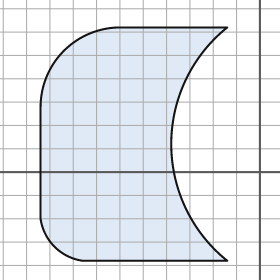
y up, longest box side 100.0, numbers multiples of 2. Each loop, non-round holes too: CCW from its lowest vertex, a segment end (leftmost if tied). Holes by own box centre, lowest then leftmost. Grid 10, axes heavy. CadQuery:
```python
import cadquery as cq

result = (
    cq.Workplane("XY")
    .moveTo(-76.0, -38.0)
    .lineTo(-14.0, -38.0)
    .threePointArc((-38.0, 12.0), (-14.0, 62.0))
    .lineTo(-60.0, 62.0)
    .threePointArc((-84.0, 52.0), (-94.0, 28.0))
    .lineTo(-94.0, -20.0)
    .threePointArc((-88.0, -32.0), (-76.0, -38.0))
    .close()
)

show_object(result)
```